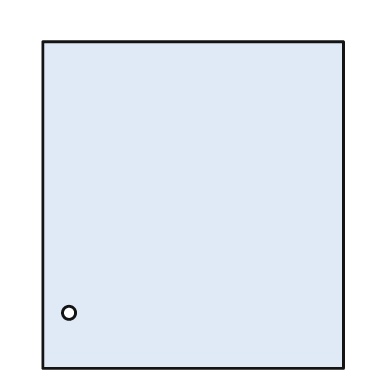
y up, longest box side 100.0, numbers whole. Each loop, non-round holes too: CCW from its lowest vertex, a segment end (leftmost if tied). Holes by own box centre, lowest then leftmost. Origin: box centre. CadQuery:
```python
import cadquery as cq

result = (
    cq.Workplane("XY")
    .moveTo(-46.0, -50.0)
    .lineTo(46.0, -50.0)
    .lineTo(46.0, 50.0)
    .lineTo(-46.0, 50.0)
    .close()
    .moveTo(-38.0, -33.0)
    .circle(2.0)
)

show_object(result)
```